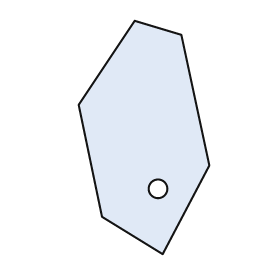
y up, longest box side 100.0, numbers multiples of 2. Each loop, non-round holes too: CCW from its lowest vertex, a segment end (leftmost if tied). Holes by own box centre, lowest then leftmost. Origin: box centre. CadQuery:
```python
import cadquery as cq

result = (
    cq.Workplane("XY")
    .moveTo(8.0, -50.0)
    .lineTo(28.0, -12.0)
    .lineTo(16.0, 44.0)
    .lineTo(-4.0, 50.0)
    .lineTo(-28.0, 14.0)
    .lineTo(-18.0, -34.0)
    .close()
    .moveTo(6.0, -22.0)
    .circle(4.0)
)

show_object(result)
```